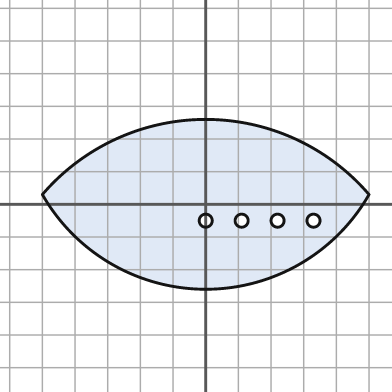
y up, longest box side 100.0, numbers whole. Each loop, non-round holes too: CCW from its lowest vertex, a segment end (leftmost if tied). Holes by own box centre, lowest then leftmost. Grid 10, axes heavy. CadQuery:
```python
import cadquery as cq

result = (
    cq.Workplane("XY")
    .moveTo(-50.0, 3.0)
    .threePointArc((0.0, -26.0), (50.0, 3.0))
    .threePointArc((0.0, 26.0), (-50.0, 3.0))
    .close()
    .moveTo(0.0, -5.0)
    .circle(2.0)
    .moveTo(11.0, -5.0)
    .circle(2.0)
    .moveTo(22.0, -5.0)
    .circle(2.0)
    .moveTo(33.0, -5.0)
    .circle(2.0)
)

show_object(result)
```